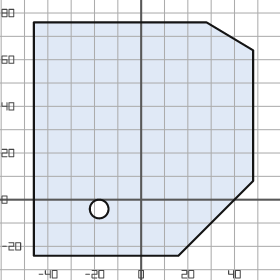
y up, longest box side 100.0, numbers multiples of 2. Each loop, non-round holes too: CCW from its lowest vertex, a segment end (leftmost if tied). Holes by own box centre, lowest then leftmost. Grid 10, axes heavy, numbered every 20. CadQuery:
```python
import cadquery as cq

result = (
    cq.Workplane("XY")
    .moveTo(-46.0, -24.0)
    .lineTo(16.0, -24.0)
    .lineTo(48.0, 8.0)
    .lineTo(48.0, 64.0)
    .lineTo(28.0, 76.0)
    .lineTo(-46.0, 76.0)
    .close()
    .moveTo(-18.0, -4.0)
    .circle(4.0)
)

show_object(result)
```